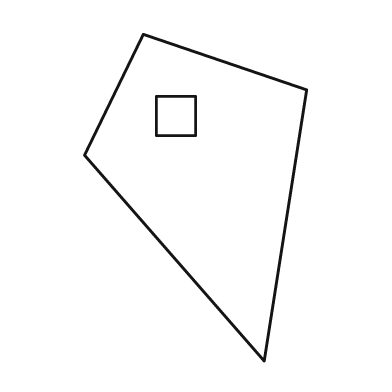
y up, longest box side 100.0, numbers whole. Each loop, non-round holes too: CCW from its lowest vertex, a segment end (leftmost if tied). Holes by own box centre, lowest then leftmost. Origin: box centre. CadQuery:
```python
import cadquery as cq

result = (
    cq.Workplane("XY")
    .moveTo(21.0, -50.0)
    .lineTo(34.0, 33.0)
    .lineTo(-16.0, 50.0)
    .lineTo(-34.0, 13.0)
    .close()
    .moveTo(-12.0, 19.0)
    .lineTo(0.0, 19.0)
    .lineTo(0.0, 31.0)
    .lineTo(-12.0, 31.0)
    .close()
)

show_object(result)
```